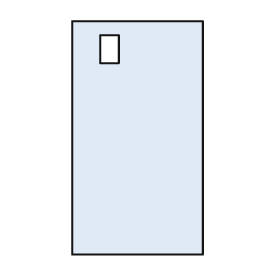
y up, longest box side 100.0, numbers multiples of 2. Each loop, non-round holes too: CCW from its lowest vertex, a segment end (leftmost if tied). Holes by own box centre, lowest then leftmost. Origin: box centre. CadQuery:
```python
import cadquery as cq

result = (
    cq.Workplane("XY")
    .moveTo(-28.0, -50.0)
    .lineTo(28.0, -50.0)
    .lineTo(28.0, 50.0)
    .lineTo(-28.0, 50.0)
    .close()
    .moveTo(-16.0, 32.0)
    .lineTo(-8.0, 32.0)
    .lineTo(-8.0, 44.0)
    .lineTo(-16.0, 44.0)
    .close()
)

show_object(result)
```